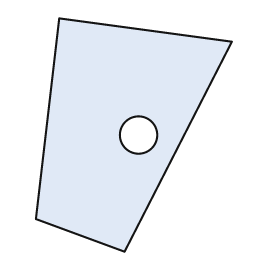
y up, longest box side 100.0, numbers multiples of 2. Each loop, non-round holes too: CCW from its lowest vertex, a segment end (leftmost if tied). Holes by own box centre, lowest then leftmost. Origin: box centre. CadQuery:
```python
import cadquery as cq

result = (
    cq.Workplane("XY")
    .moveTo(-4.0, -50.0)
    .lineTo(42.0, 40.0)
    .lineTo(-32.0, 50.0)
    .lineTo(-42.0, -36.0)
    .close()
    .moveTo(2.0, 0.0)
    .circle(8.0)
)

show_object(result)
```